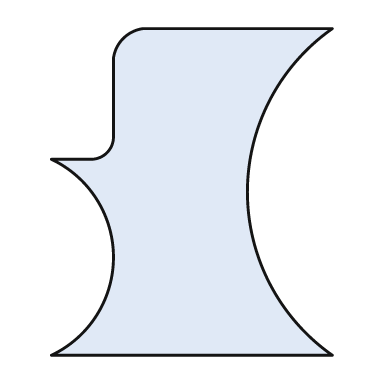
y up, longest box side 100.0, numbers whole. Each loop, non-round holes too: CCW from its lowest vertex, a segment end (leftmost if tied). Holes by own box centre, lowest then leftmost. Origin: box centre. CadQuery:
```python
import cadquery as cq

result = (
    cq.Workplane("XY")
    .moveTo(-43.0, -50.0)
    .lineTo(43.0, -50.0)
    .threePointArc((17.0, 0.0), (43.0, 50.0))
    .lineTo(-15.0, 50.0)
    .threePointArc((-21.0, 47.0), (-24.0, 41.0))
    .lineTo(-24.0, 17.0)
    .threePointArc((-26.0, 12.0), (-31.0, 10.0))
    .lineTo(-43.0, 10.0)
    .threePointArc((-24.0, -20.0), (-43.0, -50.0))
    .close()
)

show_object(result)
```